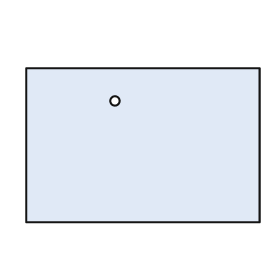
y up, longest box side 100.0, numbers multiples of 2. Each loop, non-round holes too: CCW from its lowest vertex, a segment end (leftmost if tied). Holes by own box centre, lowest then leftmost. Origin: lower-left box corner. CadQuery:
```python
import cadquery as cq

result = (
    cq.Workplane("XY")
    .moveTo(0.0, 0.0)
    .lineTo(100.0, 0.0)
    .lineTo(100.0, 66.0)
    .lineTo(0.0, 66.0)
    .close()
    .moveTo(38.0, 52.0)
    .circle(2.0)
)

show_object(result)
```